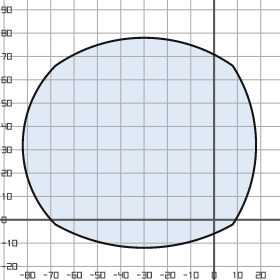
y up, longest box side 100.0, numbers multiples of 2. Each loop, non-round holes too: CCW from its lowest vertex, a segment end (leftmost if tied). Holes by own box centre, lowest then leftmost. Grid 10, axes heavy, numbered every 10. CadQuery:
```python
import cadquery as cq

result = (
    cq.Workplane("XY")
    .moveTo(-68.0, -2.0)
    .threePointArc((-30.0, -12.0), (8.0, -2.0))
    .threePointArc((18.0, 32.0), (8.0, 66.0))
    .threePointArc((-30.0, 78.0), (-68.0, 66.0))
    .threePointArc((-82.0, 32.0), (-68.0, -2.0))
    .close()
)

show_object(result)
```